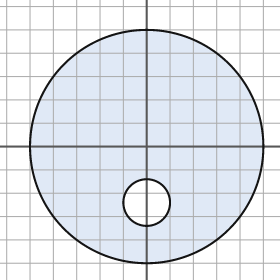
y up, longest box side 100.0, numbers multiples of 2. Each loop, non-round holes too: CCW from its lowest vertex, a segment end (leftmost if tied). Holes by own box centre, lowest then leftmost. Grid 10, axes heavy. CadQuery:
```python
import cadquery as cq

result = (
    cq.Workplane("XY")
    .moveTo(0.0, 0.0)
    .circle(50.0)
    .moveTo(0.0, -24.0)
    .circle(10.0)
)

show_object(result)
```